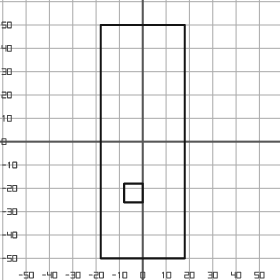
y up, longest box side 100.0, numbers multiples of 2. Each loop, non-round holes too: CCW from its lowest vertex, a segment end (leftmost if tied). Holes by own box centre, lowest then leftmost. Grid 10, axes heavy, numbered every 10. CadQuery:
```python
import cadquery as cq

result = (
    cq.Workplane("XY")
    .moveTo(-18.0, -50.0)
    .lineTo(18.0, -50.0)
    .lineTo(18.0, 50.0)
    .lineTo(-18.0, 50.0)
    .close()
    .moveTo(-8.0, -26.0)
    .lineTo(0.0, -26.0)
    .lineTo(0.0, -18.0)
    .lineTo(-8.0, -18.0)
    .close()
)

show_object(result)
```